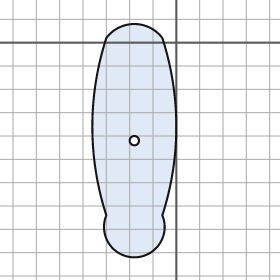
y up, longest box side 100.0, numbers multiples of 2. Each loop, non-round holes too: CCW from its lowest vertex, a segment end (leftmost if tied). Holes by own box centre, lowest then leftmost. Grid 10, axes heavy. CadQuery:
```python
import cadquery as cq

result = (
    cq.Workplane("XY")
    .moveTo(-30.0, -74.0)
    .threePointArc((-18.0, -92.0), (-6.0, -74.0))
    .threePointArc((0.0, -36.0), (-6.0, 2.0))
    .threePointArc((-18.0, 8.0), (-30.0, 2.0))
    .threePointArc((-36.0, -36.0), (-30.0, -74.0))
    .close()
    .moveTo(-18.0, -42.0)
    .circle(2.0)
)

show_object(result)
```